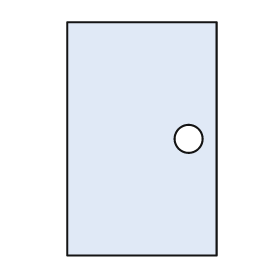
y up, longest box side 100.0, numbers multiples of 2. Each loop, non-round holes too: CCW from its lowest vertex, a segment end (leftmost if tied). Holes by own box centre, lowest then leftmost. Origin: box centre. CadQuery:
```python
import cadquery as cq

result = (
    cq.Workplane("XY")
    .moveTo(-32.0, -50.0)
    .lineTo(32.0, -50.0)
    .lineTo(32.0, 50.0)
    .lineTo(-32.0, 50.0)
    .close()
    .moveTo(20.0, 0.0)
    .circle(6.0)
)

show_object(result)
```